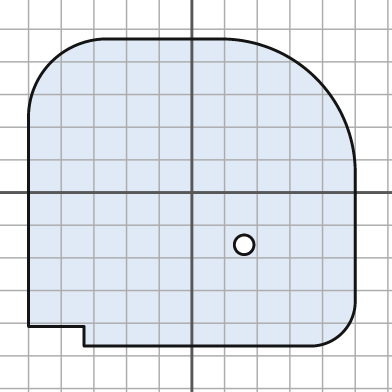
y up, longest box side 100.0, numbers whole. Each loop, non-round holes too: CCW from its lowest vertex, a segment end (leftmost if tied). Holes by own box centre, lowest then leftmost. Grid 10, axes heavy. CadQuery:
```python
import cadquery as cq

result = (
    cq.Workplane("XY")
    .moveTo(-33.0, -47.0)
    .lineTo(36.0, -47.0)
    .threePointArc((46.0, -43.0), (50.0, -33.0))
    .lineTo(50.0, 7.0)
    .threePointArc((38.0, 35.0), (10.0, 47.0))
    .lineTo(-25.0, 47.0)
    .threePointArc((-43.0, 40.0), (-50.0, 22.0))
    .lineTo(-50.0, -41.0)
    .lineTo(-33.0, -41.0)
    .close()
    .moveTo(16.0, -16.0)
    .circle(3.0)
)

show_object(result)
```